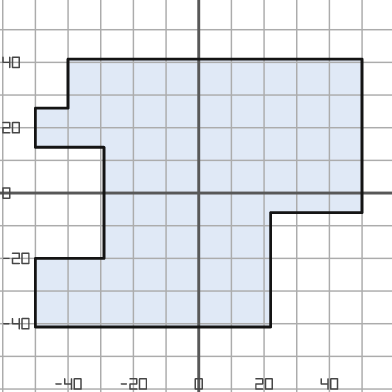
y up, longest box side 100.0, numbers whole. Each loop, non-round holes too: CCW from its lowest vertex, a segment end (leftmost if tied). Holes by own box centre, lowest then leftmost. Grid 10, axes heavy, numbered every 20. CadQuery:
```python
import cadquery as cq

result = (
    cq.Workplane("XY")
    .moveTo(-50.0, -41.0)
    .lineTo(22.0, -41.0)
    .lineTo(22.0, -6.0)
    .lineTo(50.0, -6.0)
    .lineTo(50.0, 41.0)
    .lineTo(-40.0, 41.0)
    .lineTo(-40.0, 26.0)
    .lineTo(-50.0, 26.0)
    .lineTo(-50.0, 14.0)
    .lineTo(-29.0, 14.0)
    .lineTo(-29.0, -20.0)
    .lineTo(-50.0, -20.0)
    .close()
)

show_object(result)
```